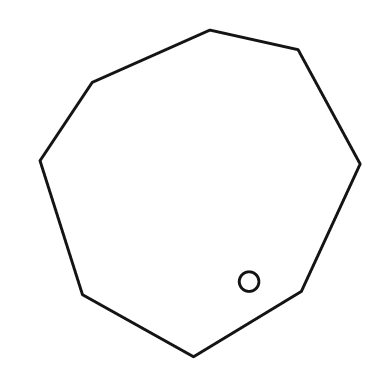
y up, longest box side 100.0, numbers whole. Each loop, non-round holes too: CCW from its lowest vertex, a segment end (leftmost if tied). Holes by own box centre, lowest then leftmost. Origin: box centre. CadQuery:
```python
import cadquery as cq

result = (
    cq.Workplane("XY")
    .moveTo(-2.0, -50.0)
    .lineTo(31.0, -30.0)
    .lineTo(49.0, 9.0)
    .lineTo(30.0, 44.0)
    .lineTo(3.0, 50.0)
    .lineTo(-33.0, 34.0)
    .lineTo(-49.0, 10.0)
    .lineTo(-36.0, -31.0)
    .close()
    .moveTo(15.0, -27.0)
    .circle(3.0)
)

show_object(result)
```